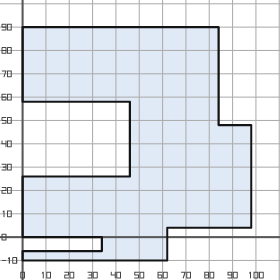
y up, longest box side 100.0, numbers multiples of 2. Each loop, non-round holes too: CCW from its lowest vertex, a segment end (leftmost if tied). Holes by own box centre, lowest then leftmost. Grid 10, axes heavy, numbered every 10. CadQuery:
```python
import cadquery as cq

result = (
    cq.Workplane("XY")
    .moveTo(0.0, -10.0)
    .lineTo(62.0, -10.0)
    .lineTo(62.0, 4.0)
    .lineTo(98.0, 4.0)
    .lineTo(98.0, 48.0)
    .lineTo(84.0, 48.0)
    .lineTo(84.0, 90.0)
    .lineTo(0.0, 90.0)
    .lineTo(0.0, 58.0)
    .lineTo(46.0, 58.0)
    .lineTo(46.0, 26.0)
    .lineTo(0.0, 26.0)
    .lineTo(0.0, 0.0)
    .lineTo(34.0, 0.0)
    .lineTo(34.0, -6.0)
    .lineTo(0.0, -6.0)
    .close()
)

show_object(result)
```